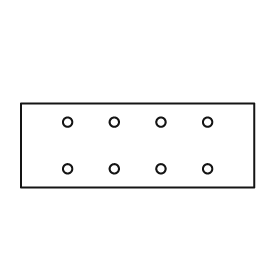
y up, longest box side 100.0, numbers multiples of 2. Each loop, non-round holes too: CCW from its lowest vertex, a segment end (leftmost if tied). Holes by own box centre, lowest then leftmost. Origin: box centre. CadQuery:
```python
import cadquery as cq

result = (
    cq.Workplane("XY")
    .moveTo(-50.0, -18.0)
    .lineTo(50.0, -18.0)
    .lineTo(50.0, 18.0)
    .lineTo(-50.0, 18.0)
    .close()
    .moveTo(-30.0, -10.0)
    .circle(2.0)
    .moveTo(-10.0, -10.0)
    .circle(2.0)
    .moveTo(10.0, -10.0)
    .circle(2.0)
    .moveTo(30.0, -10.0)
    .circle(2.0)
    .moveTo(-30.0, 10.0)
    .circle(2.0)
    .moveTo(-10.0, 10.0)
    .circle(2.0)
    .moveTo(10.0, 10.0)
    .circle(2.0)
    .moveTo(30.0, 10.0)
    .circle(2.0)
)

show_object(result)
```